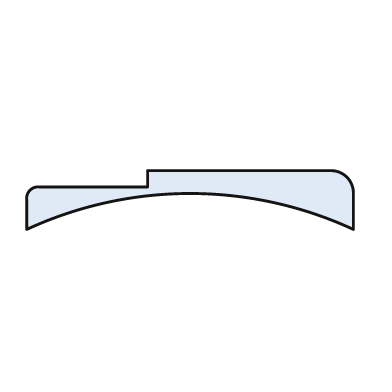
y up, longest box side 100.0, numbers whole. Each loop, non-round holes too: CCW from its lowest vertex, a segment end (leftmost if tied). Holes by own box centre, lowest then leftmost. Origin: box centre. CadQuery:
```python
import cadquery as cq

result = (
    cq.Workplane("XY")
    .moveTo(-50.0, -9.0)
    .threePointArc((0.0, 2.0), (50.0, -9.0))
    .lineTo(50.0, 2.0)
    .threePointArc((48.0, 7.0), (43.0, 9.0))
    .lineTo(-13.0, 9.0)
    .lineTo(-13.0, 4.0)
    .lineTo(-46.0, 4.0)
    .threePointArc((-49.0, 3.0), (-50.0, 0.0))
    .close()
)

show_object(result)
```